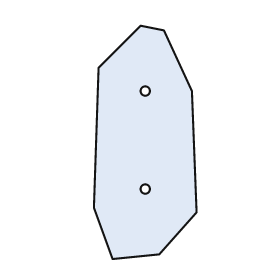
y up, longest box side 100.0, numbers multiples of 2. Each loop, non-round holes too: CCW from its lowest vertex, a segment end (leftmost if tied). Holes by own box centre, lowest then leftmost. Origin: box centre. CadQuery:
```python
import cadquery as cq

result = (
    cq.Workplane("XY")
    .moveTo(-14.0, -50.0)
    .lineTo(6.0, -48.0)
    .lineTo(22.0, -30.0)
    .lineTo(20.0, 22.0)
    .lineTo(8.0, 48.0)
    .lineTo(-2.0, 50.0)
    .lineTo(-20.0, 32.0)
    .lineTo(-22.0, -28.0)
    .close()
    .moveTo(0.0, -20.0)
    .circle(2.0)
    .moveTo(0.0, 22.0)
    .circle(2.0)
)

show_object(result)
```